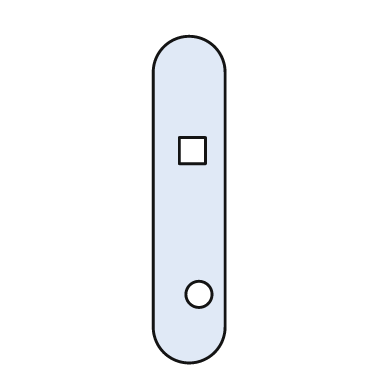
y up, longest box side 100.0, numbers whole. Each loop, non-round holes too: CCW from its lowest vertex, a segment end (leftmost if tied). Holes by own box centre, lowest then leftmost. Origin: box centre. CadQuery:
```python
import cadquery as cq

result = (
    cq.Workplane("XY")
    .moveTo(-11.0, -39.0)
    .threePointArc((0.0, -50.0), (11.0, -39.0))
    .lineTo(11.0, 39.0)
    .threePointArc((0.0, 50.0), (-11.0, 39.0))
    .close()
    .moveTo(3.0, -29.0)
    .circle(4.0)
    .moveTo(-3.0, 11.0)
    .lineTo(5.0, 11.0)
    .lineTo(5.0, 19.0)
    .lineTo(-3.0, 19.0)
    .close()
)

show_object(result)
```